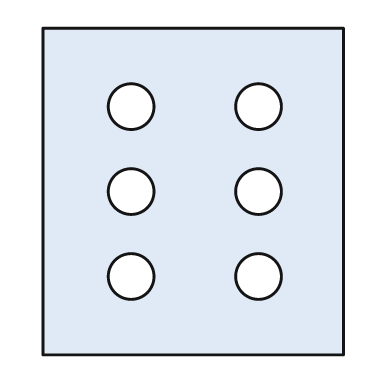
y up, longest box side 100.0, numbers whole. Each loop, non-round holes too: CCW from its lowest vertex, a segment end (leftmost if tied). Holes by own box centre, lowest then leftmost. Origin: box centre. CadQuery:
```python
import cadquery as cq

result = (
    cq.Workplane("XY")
    .moveTo(-46.0, -50.0)
    .lineTo(46.0, -50.0)
    .lineTo(46.0, 50.0)
    .lineTo(-46.0, 50.0)
    .close()
    .moveTo(-19.0, -26.0)
    .circle(7.0)
    .moveTo(20.0, -26.0)
    .circle(7.0)
    .moveTo(-19.0, 0.0)
    .circle(7.0)
    .moveTo(20.0, 0.0)
    .circle(7.0)
    .moveTo(-19.0, 26.0)
    .circle(7.0)
    .moveTo(20.0, 26.0)
    .circle(7.0)
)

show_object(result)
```